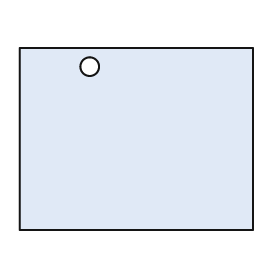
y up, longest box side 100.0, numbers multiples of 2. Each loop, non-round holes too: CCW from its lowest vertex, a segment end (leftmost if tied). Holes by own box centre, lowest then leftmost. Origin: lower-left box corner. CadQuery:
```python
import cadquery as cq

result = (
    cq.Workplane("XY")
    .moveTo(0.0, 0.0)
    .lineTo(100.0, 0.0)
    .lineTo(100.0, 78.0)
    .lineTo(0.0, 78.0)
    .close()
    .moveTo(30.0, 70.0)
    .circle(4.0)
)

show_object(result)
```